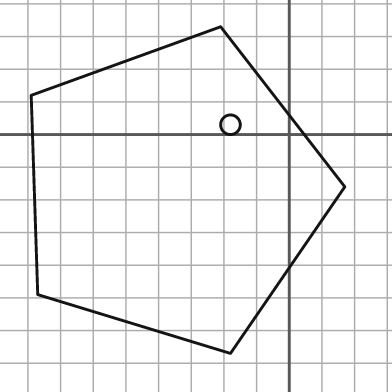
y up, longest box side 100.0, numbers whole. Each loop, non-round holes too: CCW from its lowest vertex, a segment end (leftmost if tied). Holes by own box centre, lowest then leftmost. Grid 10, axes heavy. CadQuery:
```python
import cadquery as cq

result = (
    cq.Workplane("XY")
    .moveTo(-18.0, -67.0)
    .lineTo(17.0, -16.0)
    .lineTo(-21.0, 33.0)
    .lineTo(-79.0, 12.0)
    .lineTo(-77.0, -49.0)
    .close()
    .moveTo(-18.0, 3.0)
    .circle(3.0)
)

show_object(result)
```